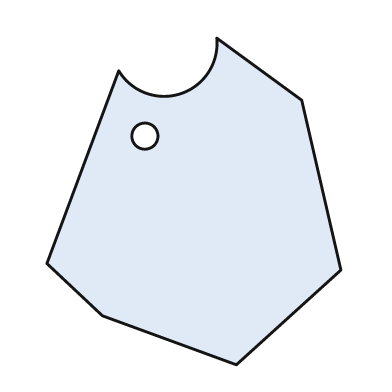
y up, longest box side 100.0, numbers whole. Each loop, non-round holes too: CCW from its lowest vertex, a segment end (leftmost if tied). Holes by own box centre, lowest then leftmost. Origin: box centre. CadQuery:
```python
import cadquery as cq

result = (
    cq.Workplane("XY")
    .moveTo(13.0, -50.0)
    .lineTo(45.0, -21.0)
    .lineTo(33.0, 31.0)
    .lineTo(7.0, 50.0)
    .threePointArc((-4.0, 33.0), (-23.0, 40.0))
    .lineTo(-45.0, -19.0)
    .lineTo(-28.0, -35.0)
    .close()
    .moveTo(-15.0, 20.0)
    .circle(4.0)
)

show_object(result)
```